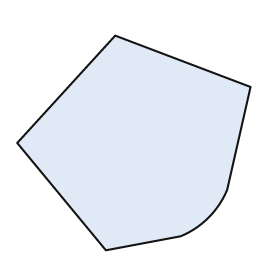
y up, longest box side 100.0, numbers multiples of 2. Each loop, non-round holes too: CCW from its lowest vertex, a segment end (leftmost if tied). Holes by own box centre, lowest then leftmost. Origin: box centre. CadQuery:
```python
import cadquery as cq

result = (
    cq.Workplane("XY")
    .moveTo(-12.0, -46.0)
    .lineTo(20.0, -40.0)
    .threePointArc((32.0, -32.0), (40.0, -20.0))
    .lineTo(50.0, 24.0)
    .lineTo(-8.0, 46.0)
    .lineTo(-50.0, 0.0)
    .close()
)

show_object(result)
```